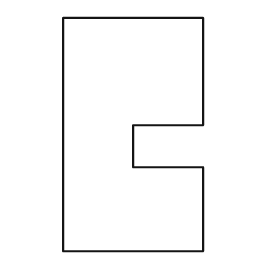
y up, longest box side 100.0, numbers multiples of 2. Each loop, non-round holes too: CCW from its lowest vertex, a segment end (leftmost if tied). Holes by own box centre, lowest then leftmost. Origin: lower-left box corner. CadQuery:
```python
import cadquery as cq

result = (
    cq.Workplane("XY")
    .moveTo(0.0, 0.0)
    .lineTo(60.0, 0.0)
    .lineTo(60.0, 36.0)
    .lineTo(30.0, 36.0)
    .lineTo(30.0, 54.0)
    .lineTo(60.0, 54.0)
    .lineTo(60.0, 100.0)
    .lineTo(0.0, 100.0)
    .close()
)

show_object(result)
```